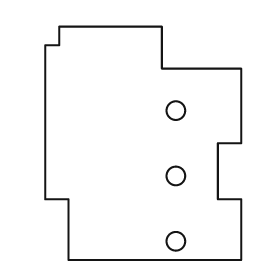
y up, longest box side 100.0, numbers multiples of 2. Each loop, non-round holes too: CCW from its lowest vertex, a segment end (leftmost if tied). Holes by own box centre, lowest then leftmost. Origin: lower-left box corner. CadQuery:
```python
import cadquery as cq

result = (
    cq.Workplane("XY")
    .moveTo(10.0, 0.0)
    .lineTo(84.0, 0.0)
    .lineTo(84.0, 26.0)
    .lineTo(74.0, 26.0)
    .lineTo(74.0, 50.0)
    .lineTo(84.0, 50.0)
    .lineTo(84.0, 82.0)
    .lineTo(50.0, 82.0)
    .lineTo(50.0, 100.0)
    .lineTo(6.0, 100.0)
    .lineTo(6.0, 92.0)
    .lineTo(0.0, 92.0)
    .lineTo(0.0, 26.0)
    .lineTo(10.0, 26.0)
    .close()
    .moveTo(56.0, 8.0)
    .circle(4.0)
    .moveTo(56.0, 36.0)
    .circle(4.0)
    .moveTo(56.0, 64.0)
    .circle(4.0)
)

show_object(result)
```